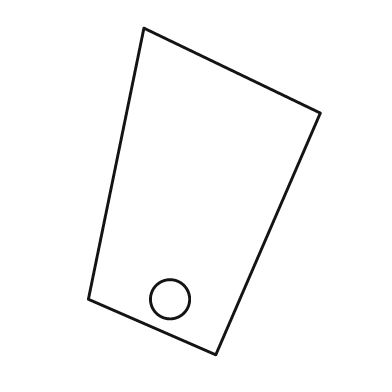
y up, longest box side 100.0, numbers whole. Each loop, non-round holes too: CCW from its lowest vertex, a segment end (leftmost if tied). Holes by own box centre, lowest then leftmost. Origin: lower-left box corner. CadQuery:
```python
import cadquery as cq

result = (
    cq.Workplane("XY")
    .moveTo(39.0, 0.0)
    .lineTo(71.0, 74.0)
    .lineTo(17.0, 100.0)
    .lineTo(0.0, 17.0)
    .close()
    .moveTo(25.0, 17.0)
    .circle(6.0)
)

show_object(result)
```